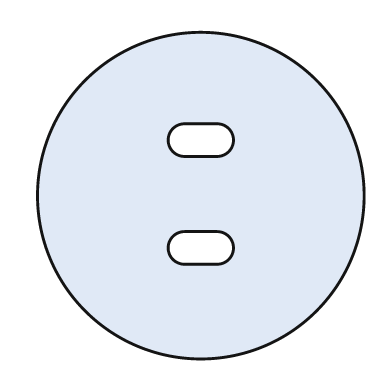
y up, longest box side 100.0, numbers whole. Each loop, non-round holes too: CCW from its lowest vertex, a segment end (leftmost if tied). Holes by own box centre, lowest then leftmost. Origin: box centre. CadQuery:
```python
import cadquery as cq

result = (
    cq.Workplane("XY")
    .moveTo(0.0, 0.0)
    .circle(50.0)
    .moveTo(-5.0, -21.0)
    .lineTo(5.0, -21.0)
    .threePointArc((10.0, -16.0), (5.0, -11.0))
    .lineTo(-5.0, -11.0)
    .threePointArc((-10.0, -16.0), (-5.0, -21.0))
    .close()
    .moveTo(-5.0, 12.0)
    .lineTo(5.0, 12.0)
    .threePointArc((10.0, 17.0), (5.0, 22.0))
    .lineTo(-5.0, 22.0)
    .threePointArc((-10.0, 17.0), (-5.0, 12.0))
    .close()
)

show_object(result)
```